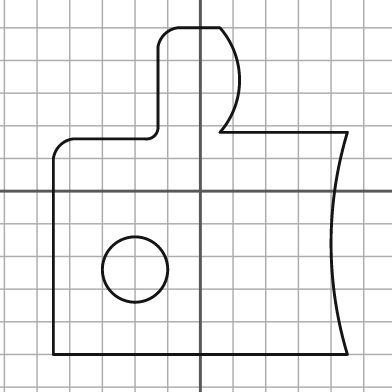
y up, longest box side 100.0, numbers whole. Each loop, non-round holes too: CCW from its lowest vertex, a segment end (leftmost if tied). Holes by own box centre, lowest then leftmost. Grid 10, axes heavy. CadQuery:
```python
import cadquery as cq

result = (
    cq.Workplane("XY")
    .moveTo(-45.0, -50.0)
    .lineTo(45.0, -50.0)
    .threePointArc((40.0, -16.0), (45.0, 18.0))
    .lineTo(6.0, 18.0)
    .threePointArc((12.0, 34.0), (6.0, 50.0))
    .lineTo(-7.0, 50.0)
    .threePointArc((-11.0, 48.0), (-13.0, 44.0))
    .lineTo(-13.0, 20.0)
    .threePointArc((-14.0, 17.0), (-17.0, 16.0))
    .lineTo(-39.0, 16.0)
    .threePointArc((-43.0, 14.0), (-45.0, 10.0))
    .close()
    .moveTo(-20.0, -24.0)
    .circle(10.0)
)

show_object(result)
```